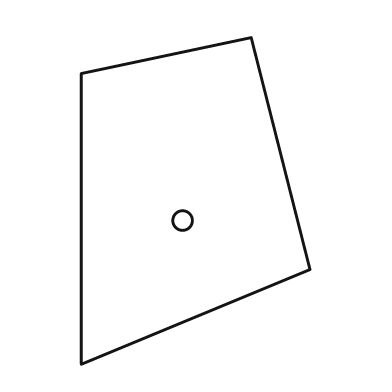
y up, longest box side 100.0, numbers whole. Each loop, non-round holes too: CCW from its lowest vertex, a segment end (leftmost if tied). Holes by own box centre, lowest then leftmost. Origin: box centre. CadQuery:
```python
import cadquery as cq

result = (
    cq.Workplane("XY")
    .moveTo(-35.0, -50.0)
    .lineTo(35.0, -21.0)
    .lineTo(17.0, 50.0)
    .lineTo(-35.0, 39.0)
    .close()
    .moveTo(-4.0, -6.0)
    .circle(3.0)
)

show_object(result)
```